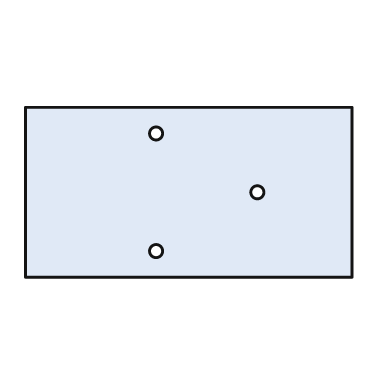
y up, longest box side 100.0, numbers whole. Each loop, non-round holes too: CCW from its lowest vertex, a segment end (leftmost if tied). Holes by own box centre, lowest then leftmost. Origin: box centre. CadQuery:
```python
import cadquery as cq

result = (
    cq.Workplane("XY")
    .moveTo(-50.0, -26.0)
    .lineTo(50.0, -26.0)
    .lineTo(50.0, 26.0)
    .lineTo(-50.0, 26.0)
    .close()
    .moveTo(-10.0, -18.0)
    .circle(2.0)
    .moveTo(21.0, 0.0)
    .circle(2.0)
    .moveTo(-10.0, 18.0)
    .circle(2.0)
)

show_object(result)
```